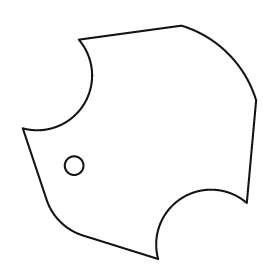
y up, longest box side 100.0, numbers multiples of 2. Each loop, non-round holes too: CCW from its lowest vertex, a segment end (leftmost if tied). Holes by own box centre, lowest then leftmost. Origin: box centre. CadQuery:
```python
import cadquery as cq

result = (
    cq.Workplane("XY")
    .moveTo(8.0, -50.0)
    .threePointArc((18.0, -24.0), (46.0, -26.0))
    .lineTo(50.0, 18.0)
    .threePointArc((38.0, 38.0), (18.0, 50.0))
    .lineTo(-26.0, 44.0)
    .threePointArc((-24.0, 16.0), (-50.0, 6.0))
    .lineTo(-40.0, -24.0)
    .threePointArc((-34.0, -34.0), (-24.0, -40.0))
    .close()
    .moveTo(-28.0, -10.0)
    .circle(4.0)
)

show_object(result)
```